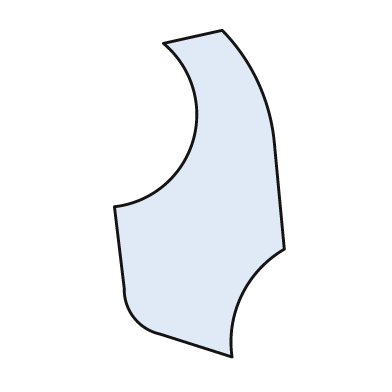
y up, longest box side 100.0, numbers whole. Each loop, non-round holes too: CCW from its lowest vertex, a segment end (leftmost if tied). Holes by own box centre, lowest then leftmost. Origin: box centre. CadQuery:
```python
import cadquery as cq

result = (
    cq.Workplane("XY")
    .moveTo(10.0, -50.0)
    .threePointArc((13.0, -31.0), (26.0, -17.0))
    .lineTo(23.0, 15.0)
    .threePointArc((18.0, 34.0), (7.0, 50.0))
    .lineTo(-11.0, 46.0)
    .threePointArc((-2.0, 16.0), (-26.0, -4.0))
    .lineTo(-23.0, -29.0)
    .threePointArc((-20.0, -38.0), (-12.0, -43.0))
    .close()
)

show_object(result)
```